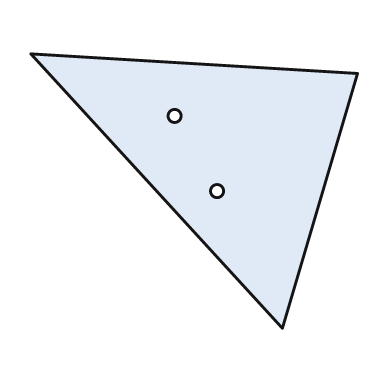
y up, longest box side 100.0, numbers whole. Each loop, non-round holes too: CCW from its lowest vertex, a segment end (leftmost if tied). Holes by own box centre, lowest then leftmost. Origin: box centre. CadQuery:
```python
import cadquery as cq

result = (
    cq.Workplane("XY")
    .moveTo(27.0, -42.0)
    .lineTo(50.0, 36.0)
    .lineTo(-50.0, 42.0)
    .close()
    .moveTo(7.0, 0.0)
    .circle(2.0)
    .moveTo(-6.0, 23.0)
    .circle(2.0)
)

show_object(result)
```